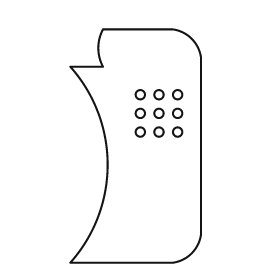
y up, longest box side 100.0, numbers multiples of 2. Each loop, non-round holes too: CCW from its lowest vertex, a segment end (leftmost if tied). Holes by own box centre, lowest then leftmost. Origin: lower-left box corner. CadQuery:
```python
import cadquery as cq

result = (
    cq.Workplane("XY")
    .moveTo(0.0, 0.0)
    .lineTo(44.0, 0.0)
    .threePointArc((52.0, 4.0), (56.0, 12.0))
    .lineTo(56.0, 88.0)
    .threePointArc((52.0, 96.0), (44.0, 100.0))
    .lineTo(14.0, 100.0)
    .threePointArc((12.0, 92.0), (14.0, 84.0))
    .lineTo(0.0, 84.0)
    .threePointArc((16.0, 42.0), (0.0, 0.0))
    .close()
    .moveTo(30.0, 56.0)
    .circle(2.0)
    .moveTo(38.0, 56.0)
    .circle(2.0)
    .moveTo(46.0, 56.0)
    .circle(2.0)
    .moveTo(30.0, 64.0)
    .circle(2.0)
    .moveTo(38.0, 64.0)
    .circle(2.0)
    .moveTo(46.0, 64.0)
    .circle(2.0)
    .moveTo(30.0, 72.0)
    .circle(2.0)
    .moveTo(38.0, 72.0)
    .circle(2.0)
    .moveTo(46.0, 72.0)
    .circle(2.0)
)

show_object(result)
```